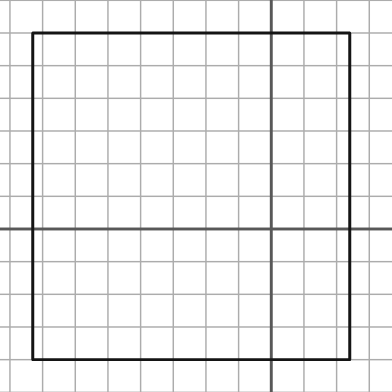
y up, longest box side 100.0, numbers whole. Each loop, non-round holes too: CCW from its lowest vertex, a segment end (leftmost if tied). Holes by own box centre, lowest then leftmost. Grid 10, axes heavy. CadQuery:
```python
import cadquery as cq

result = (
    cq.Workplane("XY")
    .moveTo(-73.0, -40.0)
    .lineTo(24.0, -40.0)
    .lineTo(24.0, 60.0)
    .lineTo(-73.0, 60.0)
    .close()
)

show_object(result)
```